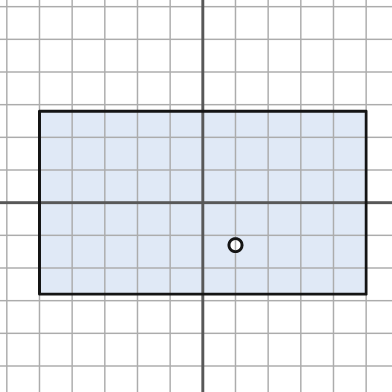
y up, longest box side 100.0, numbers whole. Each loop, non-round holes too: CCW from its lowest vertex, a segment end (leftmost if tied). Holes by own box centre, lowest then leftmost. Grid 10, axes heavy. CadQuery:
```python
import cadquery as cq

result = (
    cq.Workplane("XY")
    .moveTo(-50.0, -28.0)
    .lineTo(50.0, -28.0)
    .lineTo(50.0, 28.0)
    .lineTo(-50.0, 28.0)
    .close()
    .moveTo(10.0, -13.0)
    .circle(2.0)
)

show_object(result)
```